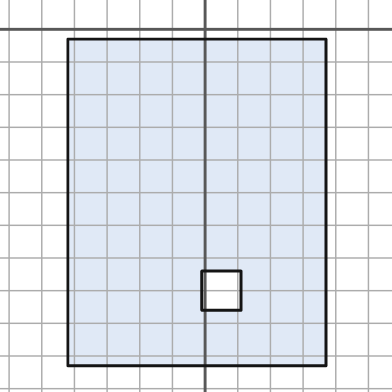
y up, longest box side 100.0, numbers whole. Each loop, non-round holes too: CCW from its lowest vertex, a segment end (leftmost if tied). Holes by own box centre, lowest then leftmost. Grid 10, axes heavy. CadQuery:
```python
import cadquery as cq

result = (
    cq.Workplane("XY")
    .moveTo(-42.0, -103.0)
    .lineTo(37.0, -103.0)
    .lineTo(37.0, -3.0)
    .lineTo(-42.0, -3.0)
    .close()
    .moveTo(-1.0, -86.0)
    .lineTo(11.0, -86.0)
    .lineTo(11.0, -74.0)
    .lineTo(-1.0, -74.0)
    .close()
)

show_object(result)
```